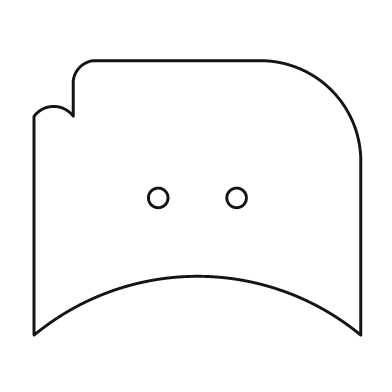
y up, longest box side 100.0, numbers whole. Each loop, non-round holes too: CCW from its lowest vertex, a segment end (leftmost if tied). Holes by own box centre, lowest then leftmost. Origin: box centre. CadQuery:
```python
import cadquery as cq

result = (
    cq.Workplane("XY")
    .moveTo(-50.0, -42.0)
    .threePointArc((0.0, -24.0), (50.0, -42.0))
    .lineTo(50.0, 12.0)
    .threePointArc((41.0, 33.0), (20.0, 42.0))
    .lineTo(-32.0, 42.0)
    .threePointArc((-36.0, 40.0), (-38.0, 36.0))
    .lineTo(-38.0, 25.0)
    .threePointArc((-44.0, 28.0), (-50.0, 25.0))
    .close()
    .moveTo(-12.0, 0.0)
    .circle(3.0)
    .moveTo(12.0, 0.0)
    .circle(3.0)
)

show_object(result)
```